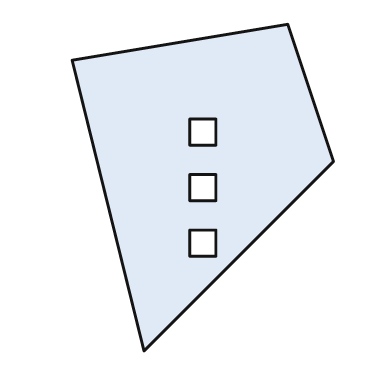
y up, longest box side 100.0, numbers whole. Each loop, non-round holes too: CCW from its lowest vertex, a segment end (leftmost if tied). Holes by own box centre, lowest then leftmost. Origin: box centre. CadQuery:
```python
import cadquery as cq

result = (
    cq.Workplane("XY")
    .moveTo(-18.0, -50.0)
    .lineTo(40.0, 8.0)
    .lineTo(26.0, 50.0)
    .lineTo(-40.0, 39.0)
    .close()
    .moveTo(-4.0, -21.0)
    .lineTo(4.0, -21.0)
    .lineTo(4.0, -13.0)
    .lineTo(-4.0, -13.0)
    .close()
    .moveTo(-4.0, -4.0)
    .lineTo(4.0, -4.0)
    .lineTo(4.0, 4.0)
    .lineTo(-4.0, 4.0)
    .close()
    .moveTo(-4.0, 13.0)
    .lineTo(4.0, 13.0)
    .lineTo(4.0, 21.0)
    .lineTo(-4.0, 21.0)
    .close()
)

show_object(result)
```